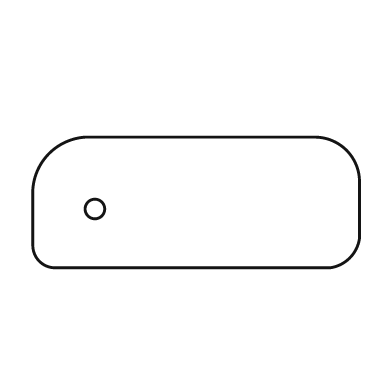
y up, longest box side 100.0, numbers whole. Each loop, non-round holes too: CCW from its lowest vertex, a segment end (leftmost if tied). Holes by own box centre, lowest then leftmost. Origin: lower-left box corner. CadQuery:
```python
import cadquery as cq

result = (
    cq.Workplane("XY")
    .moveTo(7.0, 0.0)
    .lineTo(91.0, 0.0)
    .threePointArc((97.0, 3.0), (100.0, 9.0))
    .lineTo(100.0, 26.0)
    .threePointArc((96.0, 36.0), (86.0, 40.0))
    .lineTo(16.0, 40.0)
    .threePointArc((5.0, 35.0), (0.0, 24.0))
    .lineTo(0.0, 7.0)
    .threePointArc((2.0, 2.0), (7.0, 0.0))
    .close()
    .moveTo(19.0, 18.0)
    .circle(3.0)
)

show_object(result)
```